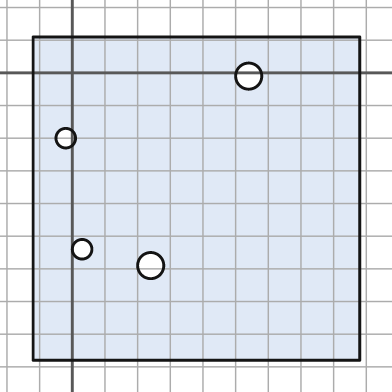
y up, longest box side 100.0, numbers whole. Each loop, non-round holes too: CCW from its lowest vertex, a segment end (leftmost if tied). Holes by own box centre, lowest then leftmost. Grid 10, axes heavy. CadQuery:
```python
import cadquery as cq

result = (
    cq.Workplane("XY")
    .moveTo(-12.0, -88.0)
    .lineTo(88.0, -88.0)
    .lineTo(88.0, 11.0)
    .lineTo(-12.0, 11.0)
    .close()
    .moveTo(24.0, -59.0)
    .circle(4.0)
    .moveTo(3.0, -54.0)
    .circle(3.0)
    .moveTo(-2.0, -20.0)
    .circle(3.0)
    .moveTo(54.0, -1.0)
    .circle(4.0)
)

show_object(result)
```